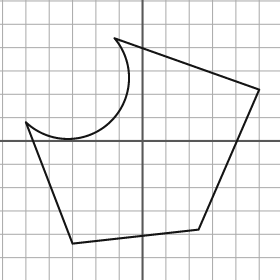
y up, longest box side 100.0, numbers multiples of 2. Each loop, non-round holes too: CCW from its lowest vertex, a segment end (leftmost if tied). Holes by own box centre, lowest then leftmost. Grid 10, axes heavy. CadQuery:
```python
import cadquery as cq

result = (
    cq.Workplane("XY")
    .moveTo(-30.0, -44.0)
    .lineTo(24.0, -38.0)
    .lineTo(50.0, 22.0)
    .lineTo(-12.0, 44.0)
    .threePointArc((-14.0, 8.0), (-50.0, 8.0))
    .close()
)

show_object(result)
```